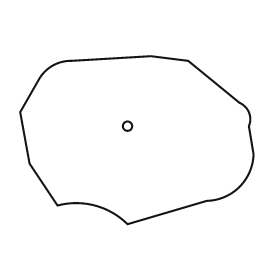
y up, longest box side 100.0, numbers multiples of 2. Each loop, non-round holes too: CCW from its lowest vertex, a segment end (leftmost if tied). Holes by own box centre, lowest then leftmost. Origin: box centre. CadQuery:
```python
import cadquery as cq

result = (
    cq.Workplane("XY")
    .moveTo(-4.0, -36.0)
    .lineTo(30.0, -26.0)
    .threePointArc((44.0, -20.0), (50.0, -6.0))
    .lineTo(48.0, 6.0)
    .threePointArc((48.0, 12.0), (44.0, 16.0))
    .lineTo(22.0, 34.0)
    .lineTo(6.0, 36.0)
    .lineTo(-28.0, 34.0)
    .threePointArc((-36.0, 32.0), (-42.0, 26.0))
    .lineTo(-50.0, 12.0)
    .lineTo(-46.0, -10.0)
    .lineTo(-34.0, -28.0)
    .threePointArc((-18.0, -28.0), (-4.0, -36.0))
    .close()
    .moveTo(-4.0, 6.0)
    .circle(2.0)
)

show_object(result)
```